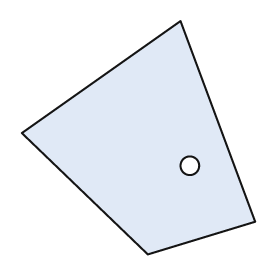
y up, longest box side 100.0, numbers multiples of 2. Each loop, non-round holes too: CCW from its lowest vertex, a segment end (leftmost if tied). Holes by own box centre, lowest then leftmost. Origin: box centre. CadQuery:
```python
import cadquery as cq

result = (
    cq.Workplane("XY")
    .moveTo(4.0, -50.0)
    .lineTo(50.0, -36.0)
    .lineTo(18.0, 50.0)
    .lineTo(-50.0, 2.0)
    .close()
    .moveTo(22.0, -12.0)
    .circle(4.0)
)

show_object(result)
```